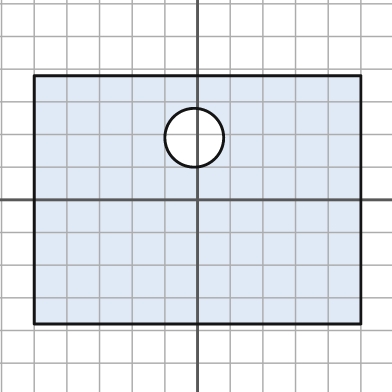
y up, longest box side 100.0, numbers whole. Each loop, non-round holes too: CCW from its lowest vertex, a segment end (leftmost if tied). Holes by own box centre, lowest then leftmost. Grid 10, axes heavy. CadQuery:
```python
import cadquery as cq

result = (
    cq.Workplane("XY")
    .moveTo(-50.0, -38.0)
    .lineTo(50.0, -38.0)
    .lineTo(50.0, 38.0)
    .lineTo(-50.0, 38.0)
    .close()
    .moveTo(-1.0, 19.0)
    .circle(9.0)
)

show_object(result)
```